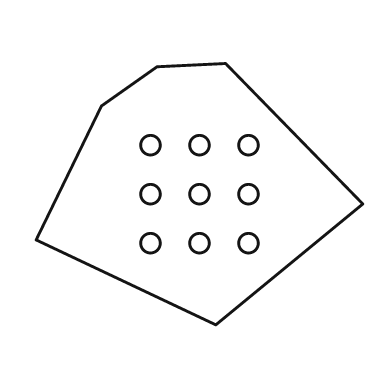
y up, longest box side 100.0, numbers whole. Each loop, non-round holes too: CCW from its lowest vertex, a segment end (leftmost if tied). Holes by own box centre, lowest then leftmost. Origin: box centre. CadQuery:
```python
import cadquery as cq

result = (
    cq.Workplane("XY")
    .moveTo(5.0, -40.0)
    .lineTo(50.0, -3.0)
    .lineTo(8.0, 40.0)
    .lineTo(-13.0, 39.0)
    .lineTo(-30.0, 27.0)
    .lineTo(-50.0, -14.0)
    .close()
    .moveTo(-15.0, -15.0)
    .circle(3.0)
    .moveTo(0.0, -15.0)
    .circle(3.0)
    .moveTo(15.0, -15.0)
    .circle(3.0)
    .moveTo(-15.0, 0.0)
    .circle(3.0)
    .moveTo(0.0, 0.0)
    .circle(3.0)
    .moveTo(15.0, 0.0)
    .circle(3.0)
    .moveTo(-15.0, 15.0)
    .circle(3.0)
    .moveTo(0.0, 15.0)
    .circle(3.0)
    .moveTo(15.0, 15.0)
    .circle(3.0)
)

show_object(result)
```